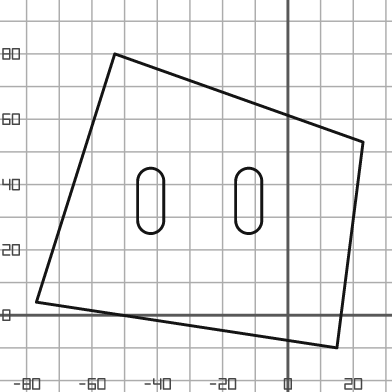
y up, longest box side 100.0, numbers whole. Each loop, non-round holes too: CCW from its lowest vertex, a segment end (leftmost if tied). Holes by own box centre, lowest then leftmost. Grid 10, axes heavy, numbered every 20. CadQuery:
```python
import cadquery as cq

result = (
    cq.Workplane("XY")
    .moveTo(15.0, -10.0)
    .lineTo(23.0, 53.0)
    .lineTo(-53.0, 80.0)
    .lineTo(-77.0, 4.0)
    .close()
    .moveTo(-46.0, 29.0)
    .threePointArc((-42.0, 25.0), (-38.0, 29.0))
    .lineTo(-38.0, 41.0)
    .threePointArc((-42.0, 45.0), (-46.0, 41.0))
    .close()
    .moveTo(-16.0, 29.0)
    .threePointArc((-12.0, 25.0), (-8.0, 29.0))
    .lineTo(-8.0, 41.0)
    .threePointArc((-12.0, 45.0), (-16.0, 41.0))
    .close()
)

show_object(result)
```